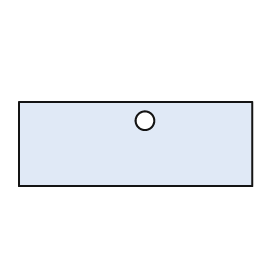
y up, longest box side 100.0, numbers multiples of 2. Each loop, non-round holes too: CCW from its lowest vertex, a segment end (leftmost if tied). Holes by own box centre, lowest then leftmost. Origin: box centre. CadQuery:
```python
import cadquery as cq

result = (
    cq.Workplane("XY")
    .moveTo(-50.0, -18.0)
    .lineTo(50.0, -18.0)
    .lineTo(50.0, 18.0)
    .lineTo(-50.0, 18.0)
    .close()
    .moveTo(4.0, 10.0)
    .circle(4.0)
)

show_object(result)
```